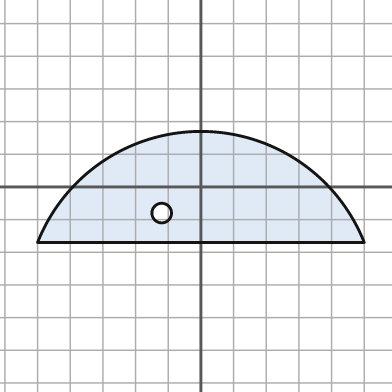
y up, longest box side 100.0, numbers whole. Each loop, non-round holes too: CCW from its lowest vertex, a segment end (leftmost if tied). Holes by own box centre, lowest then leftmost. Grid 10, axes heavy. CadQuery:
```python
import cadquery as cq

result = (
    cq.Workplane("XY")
    .moveTo(-50.0, -17.0)
    .lineTo(50.0, -17.0)
    .threePointArc((0.0, 17.0), (-50.0, -17.0))
    .close()
    .moveTo(-12.0, -8.0)
    .circle(3.0)
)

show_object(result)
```